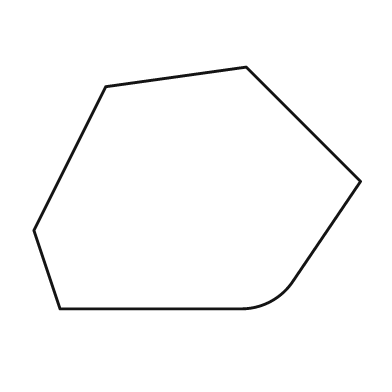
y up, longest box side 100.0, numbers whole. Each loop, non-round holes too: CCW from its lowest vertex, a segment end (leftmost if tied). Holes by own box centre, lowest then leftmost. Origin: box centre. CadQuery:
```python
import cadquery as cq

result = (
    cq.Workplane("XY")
    .moveTo(-42.0, -37.0)
    .lineTo(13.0, -37.0)
    .threePointArc((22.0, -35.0), (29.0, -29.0))
    .lineTo(50.0, 2.0)
    .lineTo(15.0, 37.0)
    .lineTo(-28.0, 31.0)
    .lineTo(-50.0, -13.0)
    .close()
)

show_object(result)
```